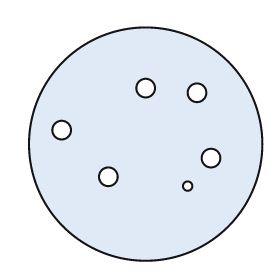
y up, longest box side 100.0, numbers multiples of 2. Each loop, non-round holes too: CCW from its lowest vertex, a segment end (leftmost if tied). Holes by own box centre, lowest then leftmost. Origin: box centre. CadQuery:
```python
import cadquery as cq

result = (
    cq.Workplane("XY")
    .moveTo(0.0, 0.0)
    .circle(50.0)
    .moveTo(18.0, -18.0)
    .circle(2.0)
    .moveTo(-16.0, -14.0)
    .circle(4.0)
    .moveTo(28.0, -6.0)
    .circle(4.0)
    .moveTo(-36.0, 6.0)
    .circle(4.0)
    .moveTo(22.0, 22.0)
    .circle(4.0)
    .moveTo(0.0, 24.0)
    .circle(4.0)
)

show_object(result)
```